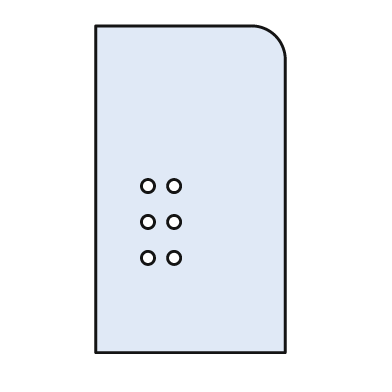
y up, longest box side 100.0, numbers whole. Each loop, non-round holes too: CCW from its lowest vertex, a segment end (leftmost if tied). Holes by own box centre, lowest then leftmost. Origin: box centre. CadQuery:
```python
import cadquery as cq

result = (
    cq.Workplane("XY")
    .moveTo(-29.0, -50.0)
    .lineTo(29.0, -50.0)
    .lineTo(29.0, 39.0)
    .threePointArc((26.0, 47.0), (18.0, 50.0))
    .lineTo(-29.0, 50.0)
    .close()
    .moveTo(-13.0, -21.0)
    .circle(2.0)
    .moveTo(-5.0, -21.0)
    .circle(2.0)
    .moveTo(-13.0, -10.0)
    .circle(2.0)
    .moveTo(-5.0, -10.0)
    .circle(2.0)
    .moveTo(-13.0, 1.0)
    .circle(2.0)
    .moveTo(-5.0, 1.0)
    .circle(2.0)
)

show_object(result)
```